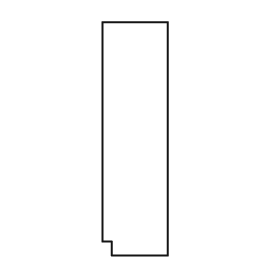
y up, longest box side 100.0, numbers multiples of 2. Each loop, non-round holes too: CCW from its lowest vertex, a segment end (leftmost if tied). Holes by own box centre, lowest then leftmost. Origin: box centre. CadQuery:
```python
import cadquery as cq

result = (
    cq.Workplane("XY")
    .moveTo(-10.0, -50.0)
    .lineTo(14.0, -50.0)
    .lineTo(14.0, 50.0)
    .lineTo(-14.0, 50.0)
    .lineTo(-14.0, -44.0)
    .lineTo(-10.0, -44.0)
    .close()
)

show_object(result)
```